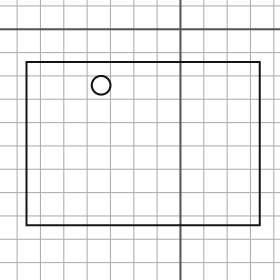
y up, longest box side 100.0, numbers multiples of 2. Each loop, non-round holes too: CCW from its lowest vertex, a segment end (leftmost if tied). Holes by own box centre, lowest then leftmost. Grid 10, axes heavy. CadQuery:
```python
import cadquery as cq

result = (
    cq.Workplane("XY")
    .moveTo(-66.0, -84.0)
    .lineTo(34.0, -84.0)
    .lineTo(34.0, -14.0)
    .lineTo(-66.0, -14.0)
    .close()
    .moveTo(-34.0, -24.0)
    .circle(4.0)
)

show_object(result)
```